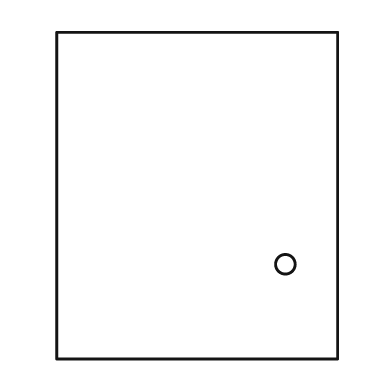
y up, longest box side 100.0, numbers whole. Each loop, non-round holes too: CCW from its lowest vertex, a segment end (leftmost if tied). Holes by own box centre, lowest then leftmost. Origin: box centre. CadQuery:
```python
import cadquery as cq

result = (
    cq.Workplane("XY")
    .moveTo(-43.0, -50.0)
    .lineTo(43.0, -50.0)
    .lineTo(43.0, 50.0)
    .lineTo(-43.0, 50.0)
    .close()
    .moveTo(27.0, -21.0)
    .circle(3.0)
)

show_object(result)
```